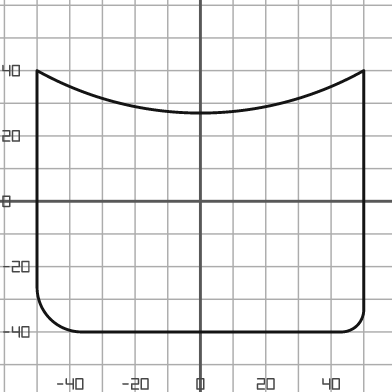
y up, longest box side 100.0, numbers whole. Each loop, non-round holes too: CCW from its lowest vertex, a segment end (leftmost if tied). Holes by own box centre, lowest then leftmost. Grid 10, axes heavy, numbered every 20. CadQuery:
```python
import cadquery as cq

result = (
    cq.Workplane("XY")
    .moveTo(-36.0, -40.0)
    .lineTo(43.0, -40.0)
    .threePointArc((48.0, -38.0), (50.0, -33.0))
    .lineTo(50.0, 40.0)
    .threePointArc((0.0, 27.0), (-50.0, 40.0))
    .lineTo(-50.0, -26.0)
    .threePointArc((-46.0, -36.0), (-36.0, -40.0))
    .close()
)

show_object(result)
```